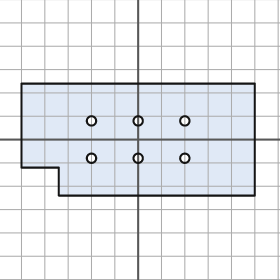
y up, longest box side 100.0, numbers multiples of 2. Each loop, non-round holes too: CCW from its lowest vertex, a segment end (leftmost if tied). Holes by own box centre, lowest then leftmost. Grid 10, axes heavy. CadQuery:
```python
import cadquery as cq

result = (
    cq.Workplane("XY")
    .moveTo(-34.0, -24.0)
    .lineTo(50.0, -24.0)
    .lineTo(50.0, 24.0)
    .lineTo(-50.0, 24.0)
    .lineTo(-50.0, -12.0)
    .lineTo(-34.0, -12.0)
    .close()
    .moveTo(-20.0, -8.0)
    .circle(2.0)
    .moveTo(0.0, -8.0)
    .circle(2.0)
    .moveTo(20.0, -8.0)
    .circle(2.0)
    .moveTo(-20.0, 8.0)
    .circle(2.0)
    .moveTo(0.0, 8.0)
    .circle(2.0)
    .moveTo(20.0, 8.0)
    .circle(2.0)
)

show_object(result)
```